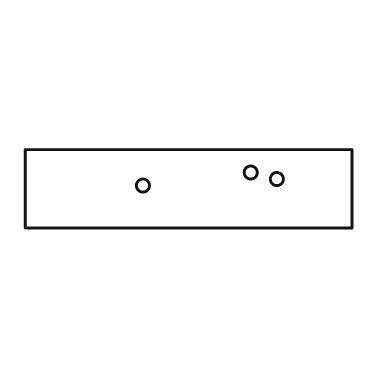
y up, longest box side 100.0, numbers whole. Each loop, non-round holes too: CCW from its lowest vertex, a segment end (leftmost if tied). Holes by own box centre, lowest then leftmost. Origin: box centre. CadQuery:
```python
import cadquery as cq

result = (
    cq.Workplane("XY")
    .moveTo(-50.0, -12.0)
    .lineTo(50.0, -12.0)
    .lineTo(50.0, 12.0)
    .lineTo(-50.0, 12.0)
    .close()
    .moveTo(-14.0, 1.0)
    .circle(2.0)
    .moveTo(27.0, 3.0)
    .circle(2.0)
    .moveTo(19.0, 5.0)
    .circle(2.0)
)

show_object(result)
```